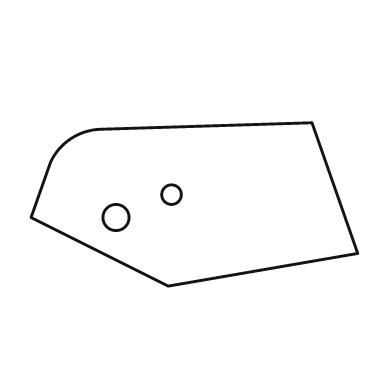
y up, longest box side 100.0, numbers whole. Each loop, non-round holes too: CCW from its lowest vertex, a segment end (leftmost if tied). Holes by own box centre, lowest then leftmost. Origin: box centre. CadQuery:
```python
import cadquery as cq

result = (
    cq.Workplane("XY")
    .moveTo(-8.0, -25.0)
    .lineTo(50.0, -15.0)
    .lineTo(36.0, 25.0)
    .lineTo(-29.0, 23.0)
    .threePointArc((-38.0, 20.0), (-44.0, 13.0))
    .lineTo(-50.0, -4.0)
    .close()
    .moveTo(-24.0, -4.0)
    .circle(4.0)
    .moveTo(-7.0, 3.0)
    .circle(3.0)
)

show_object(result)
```